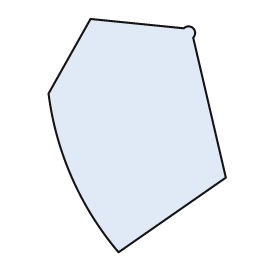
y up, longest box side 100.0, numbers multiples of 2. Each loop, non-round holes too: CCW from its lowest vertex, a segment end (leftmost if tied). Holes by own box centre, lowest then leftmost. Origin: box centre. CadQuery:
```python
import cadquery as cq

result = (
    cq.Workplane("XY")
    .moveTo(-8.0, -50.0)
    .lineTo(38.0, -18.0)
    .lineTo(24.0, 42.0)
    .threePointArc((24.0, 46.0), (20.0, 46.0))
    .lineTo(-20.0, 50.0)
    .lineTo(-38.0, 18.0)
    .threePointArc((-28.0, -18.0), (-8.0, -50.0))
    .close()
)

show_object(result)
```